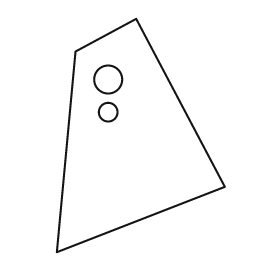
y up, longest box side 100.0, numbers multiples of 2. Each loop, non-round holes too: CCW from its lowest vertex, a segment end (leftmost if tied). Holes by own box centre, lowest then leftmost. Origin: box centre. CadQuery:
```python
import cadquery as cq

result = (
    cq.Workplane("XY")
    .moveTo(-36.0, -50.0)
    .lineTo(36.0, -22.0)
    .lineTo(-2.0, 50.0)
    .lineTo(-28.0, 36.0)
    .close()
    .moveTo(-14.0, 10.0)
    .circle(4.0)
    .moveTo(-14.0, 24.0)
    .circle(6.0)
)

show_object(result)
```